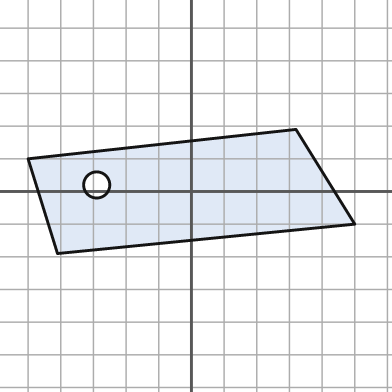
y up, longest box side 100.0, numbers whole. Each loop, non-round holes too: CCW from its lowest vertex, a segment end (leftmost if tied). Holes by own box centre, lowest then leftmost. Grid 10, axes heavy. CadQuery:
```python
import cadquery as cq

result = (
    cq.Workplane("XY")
    .moveTo(-41.0, -19.0)
    .lineTo(50.0, -10.0)
    .lineTo(32.0, 19.0)
    .lineTo(-50.0, 10.0)
    .close()
    .moveTo(-29.0, 2.0)
    .circle(4.0)
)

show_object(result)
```